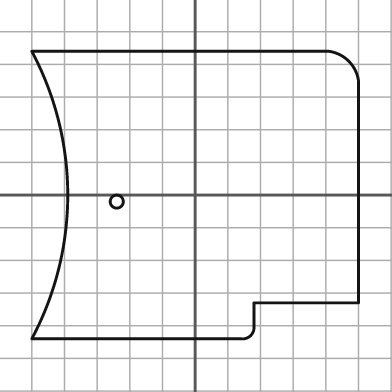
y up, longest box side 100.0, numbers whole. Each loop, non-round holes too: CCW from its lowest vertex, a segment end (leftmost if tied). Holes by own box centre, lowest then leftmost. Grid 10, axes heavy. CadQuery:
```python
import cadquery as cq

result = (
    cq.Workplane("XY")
    .moveTo(-50.0, -44.0)
    .lineTo(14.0, -44.0)
    .threePointArc((17.0, -43.0), (18.0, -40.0))
    .lineTo(18.0, -33.0)
    .lineTo(50.0, -33.0)
    .lineTo(50.0, 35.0)
    .threePointArc((47.0, 41.0), (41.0, 44.0))
    .lineTo(-50.0, 44.0)
    .threePointArc((-39.0, 0.0), (-50.0, -44.0))
    .close()
    .moveTo(-24.0, -2.0)
    .circle(2.0)
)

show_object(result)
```